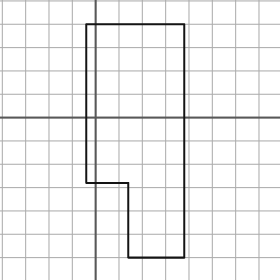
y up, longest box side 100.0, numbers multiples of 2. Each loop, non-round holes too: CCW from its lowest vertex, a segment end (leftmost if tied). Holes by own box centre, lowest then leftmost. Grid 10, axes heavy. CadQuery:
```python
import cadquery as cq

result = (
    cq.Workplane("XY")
    .moveTo(14.0, -60.0)
    .lineTo(38.0, -60.0)
    .lineTo(38.0, 40.0)
    .lineTo(-4.0, 40.0)
    .lineTo(-4.0, -28.0)
    .lineTo(14.0, -28.0)
    .close()
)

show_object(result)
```